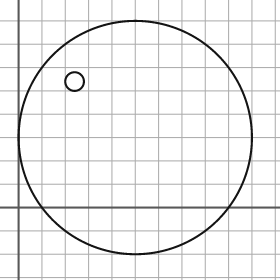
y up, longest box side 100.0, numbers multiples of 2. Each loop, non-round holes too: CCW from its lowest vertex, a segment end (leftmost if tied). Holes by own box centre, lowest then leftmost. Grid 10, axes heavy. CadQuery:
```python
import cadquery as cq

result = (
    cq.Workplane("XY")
    .moveTo(50.0, 30.0)
    .circle(50.0)
    .moveTo(24.0, 54.0)
    .circle(4.0)
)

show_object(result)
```